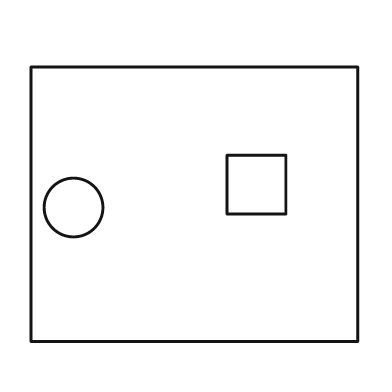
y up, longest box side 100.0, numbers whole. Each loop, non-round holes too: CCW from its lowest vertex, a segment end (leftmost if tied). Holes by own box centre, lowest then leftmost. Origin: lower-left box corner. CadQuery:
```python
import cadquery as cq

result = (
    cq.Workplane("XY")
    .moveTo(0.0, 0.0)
    .lineTo(100.0, 0.0)
    .lineTo(100.0, 84.0)
    .lineTo(0.0, 84.0)
    .close()
    .moveTo(13.0, 41.0)
    .circle(9.0)
    .moveTo(60.0, 39.0)
    .lineTo(78.0, 39.0)
    .lineTo(78.0, 57.0)
    .lineTo(60.0, 57.0)
    .close()
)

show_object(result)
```